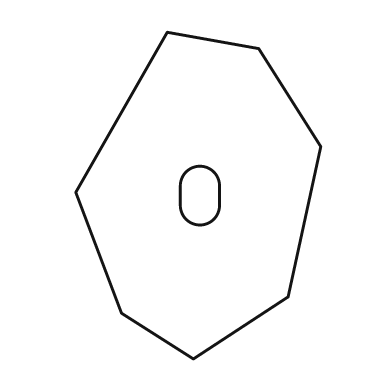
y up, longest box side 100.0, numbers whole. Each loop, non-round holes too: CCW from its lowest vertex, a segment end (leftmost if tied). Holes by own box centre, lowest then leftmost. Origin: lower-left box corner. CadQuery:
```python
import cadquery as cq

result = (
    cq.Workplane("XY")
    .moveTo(36.0, 0.0)
    .lineTo(65.0, 19.0)
    .lineTo(75.0, 65.0)
    .lineTo(56.0, 95.0)
    .lineTo(28.0, 100.0)
    .lineTo(0.0, 51.0)
    .lineTo(14.0, 14.0)
    .close()
    .moveTo(32.0, 47.0)
    .threePointArc((38.0, 41.0), (44.0, 47.0))
    .lineTo(44.0, 53.0)
    .threePointArc((38.0, 59.0), (32.0, 53.0))
    .close()
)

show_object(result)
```